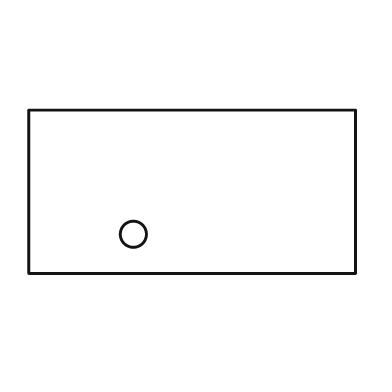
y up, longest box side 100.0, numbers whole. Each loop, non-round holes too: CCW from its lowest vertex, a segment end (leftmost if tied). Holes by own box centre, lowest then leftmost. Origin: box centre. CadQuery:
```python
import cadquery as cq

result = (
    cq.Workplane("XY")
    .moveTo(-50.0, -25.0)
    .lineTo(50.0, -25.0)
    .lineTo(50.0, 25.0)
    .lineTo(-50.0, 25.0)
    .close()
    .moveTo(-18.0, -13.0)
    .circle(4.0)
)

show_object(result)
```